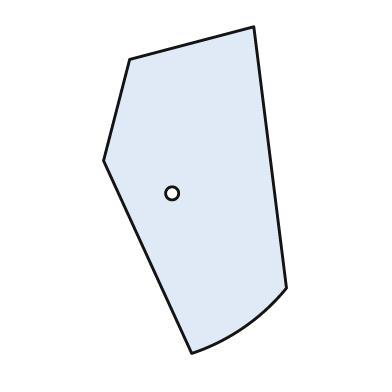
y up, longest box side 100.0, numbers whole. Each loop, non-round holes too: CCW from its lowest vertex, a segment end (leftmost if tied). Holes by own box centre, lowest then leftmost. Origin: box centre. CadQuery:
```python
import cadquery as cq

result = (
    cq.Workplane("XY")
    .moveTo(-1.0, -50.0)
    .threePointArc((15.0, -42.0), (28.0, -30.0))
    .lineTo(18.0, 50.0)
    .lineTo(-20.0, 40.0)
    .lineTo(-28.0, 9.0)
    .close()
    .moveTo(-7.0, -1.0)
    .circle(2.0)
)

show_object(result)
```